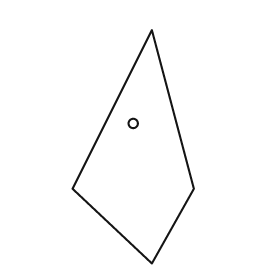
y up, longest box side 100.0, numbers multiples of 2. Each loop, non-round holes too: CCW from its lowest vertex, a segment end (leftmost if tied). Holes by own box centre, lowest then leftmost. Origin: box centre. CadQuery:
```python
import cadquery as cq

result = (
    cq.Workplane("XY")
    .moveTo(8.0, -50.0)
    .lineTo(26.0, -18.0)
    .lineTo(8.0, 50.0)
    .lineTo(-26.0, -18.0)
    .close()
    .moveTo(0.0, 10.0)
    .circle(2.0)
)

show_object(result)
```